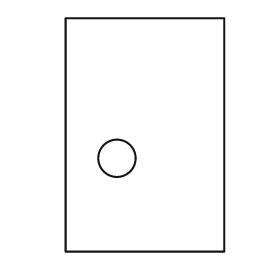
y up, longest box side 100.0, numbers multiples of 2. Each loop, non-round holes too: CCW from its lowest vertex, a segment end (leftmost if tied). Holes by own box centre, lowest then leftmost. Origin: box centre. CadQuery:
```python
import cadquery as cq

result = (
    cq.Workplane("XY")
    .moveTo(-34.0, -50.0)
    .lineTo(34.0, -50.0)
    .lineTo(34.0, 50.0)
    .lineTo(-34.0, 50.0)
    .close()
    .moveTo(-12.0, -10.0)
    .circle(8.0)
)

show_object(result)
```